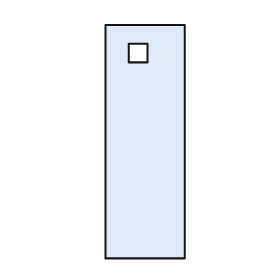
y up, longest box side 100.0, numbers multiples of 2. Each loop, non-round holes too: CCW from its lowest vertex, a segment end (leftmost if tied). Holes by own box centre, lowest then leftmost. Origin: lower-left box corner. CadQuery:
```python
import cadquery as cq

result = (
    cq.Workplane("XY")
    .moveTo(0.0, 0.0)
    .lineTo(34.0, 0.0)
    .lineTo(34.0, 100.0)
    .lineTo(0.0, 100.0)
    .close()
    .moveTo(10.0, 84.0)
    .lineTo(18.0, 84.0)
    .lineTo(18.0, 92.0)
    .lineTo(10.0, 92.0)
    .close()
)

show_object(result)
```